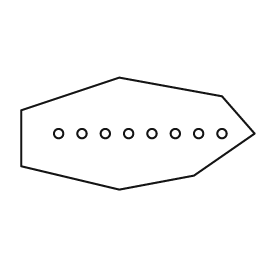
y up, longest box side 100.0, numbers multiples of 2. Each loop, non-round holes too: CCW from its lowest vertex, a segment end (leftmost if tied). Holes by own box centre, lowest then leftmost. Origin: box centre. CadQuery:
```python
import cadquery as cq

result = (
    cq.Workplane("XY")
    .moveTo(-8.0, -24.0)
    .lineTo(24.0, -18.0)
    .lineTo(50.0, 0.0)
    .lineTo(36.0, 16.0)
    .lineTo(-8.0, 24.0)
    .lineTo(-50.0, 10.0)
    .lineTo(-50.0, -14.0)
    .close()
    .moveTo(-34.0, 0.0)
    .circle(2.0)
    .moveTo(-24.0, 0.0)
    .circle(2.0)
    .moveTo(-14.0, 0.0)
    .circle(2.0)
    .moveTo(-4.0, 0.0)
    .circle(2.0)
    .moveTo(6.0, 0.0)
    .circle(2.0)
    .moveTo(16.0, 0.0)
    .circle(2.0)
    .moveTo(26.0, 0.0)
    .circle(2.0)
    .moveTo(36.0, 0.0)
    .circle(2.0)
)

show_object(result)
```